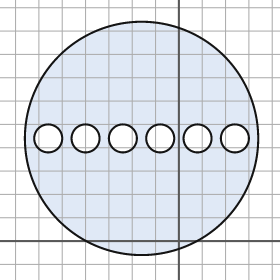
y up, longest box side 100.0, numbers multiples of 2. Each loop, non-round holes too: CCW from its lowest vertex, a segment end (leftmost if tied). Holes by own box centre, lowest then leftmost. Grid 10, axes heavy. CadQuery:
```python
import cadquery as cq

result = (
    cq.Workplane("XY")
    .moveTo(-16.0, 44.0)
    .circle(50.0)
    .moveTo(-56.0, 44.0)
    .circle(6.0)
    .moveTo(-40.0, 44.0)
    .circle(6.0)
    .moveTo(-24.0, 44.0)
    .circle(6.0)
    .moveTo(-8.0, 44.0)
    .circle(6.0)
    .moveTo(8.0, 44.0)
    .circle(6.0)
    .moveTo(24.0, 44.0)
    .circle(6.0)
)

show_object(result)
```